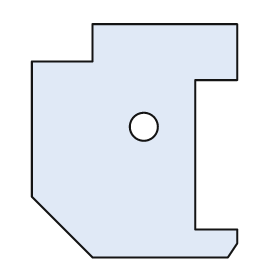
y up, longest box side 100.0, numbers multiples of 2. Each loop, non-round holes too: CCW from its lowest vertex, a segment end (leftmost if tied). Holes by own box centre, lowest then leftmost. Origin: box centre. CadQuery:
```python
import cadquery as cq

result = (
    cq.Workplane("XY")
    .moveTo(-18.0, -50.0)
    .lineTo(40.0, -50.0)
    .lineTo(44.0, -44.0)
    .lineTo(44.0, -38.0)
    .lineTo(26.0, -38.0)
    .lineTo(26.0, 26.0)
    .lineTo(44.0, 26.0)
    .lineTo(44.0, 50.0)
    .lineTo(-18.0, 50.0)
    .lineTo(-18.0, 34.0)
    .lineTo(-44.0, 34.0)
    .lineTo(-44.0, -24.0)
    .close()
    .moveTo(4.0, 6.0)
    .circle(6.0)
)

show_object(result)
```